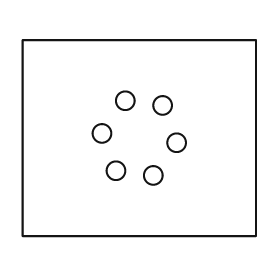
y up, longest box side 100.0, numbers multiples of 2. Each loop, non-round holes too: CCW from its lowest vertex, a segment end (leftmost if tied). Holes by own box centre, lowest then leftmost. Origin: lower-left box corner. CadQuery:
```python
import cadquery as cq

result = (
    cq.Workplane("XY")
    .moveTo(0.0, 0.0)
    .lineTo(100.0, 0.0)
    .lineTo(100.0, 84.0)
    .lineTo(0.0, 84.0)
    .close()
    .moveTo(56.0, 26.0)
    .circle(4.0)
    .moveTo(40.0, 28.0)
    .circle(4.0)
    .moveTo(66.0, 40.0)
    .circle(4.0)
    .moveTo(34.0, 44.0)
    .circle(4.0)
    .moveTo(60.0, 56.0)
    .circle(4.0)
    .moveTo(44.0, 58.0)
    .circle(4.0)
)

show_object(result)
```